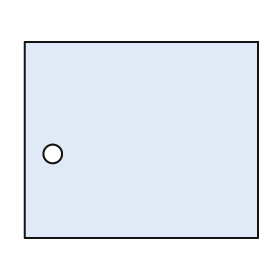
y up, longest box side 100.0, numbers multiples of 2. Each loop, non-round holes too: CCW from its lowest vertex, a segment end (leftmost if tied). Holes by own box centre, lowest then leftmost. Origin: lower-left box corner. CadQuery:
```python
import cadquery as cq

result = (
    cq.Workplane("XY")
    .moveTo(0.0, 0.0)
    .lineTo(100.0, 0.0)
    .lineTo(100.0, 84.0)
    .lineTo(0.0, 84.0)
    .close()
    .moveTo(12.0, 36.0)
    .circle(4.0)
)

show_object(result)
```